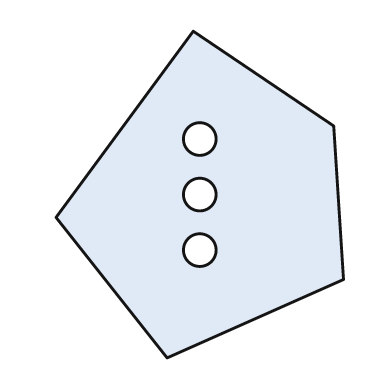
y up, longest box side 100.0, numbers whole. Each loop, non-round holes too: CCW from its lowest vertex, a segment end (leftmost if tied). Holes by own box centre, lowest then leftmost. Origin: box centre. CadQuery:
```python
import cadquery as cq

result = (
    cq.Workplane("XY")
    .moveTo(-10.0, -50.0)
    .lineTo(44.0, -26.0)
    .lineTo(41.0, 21.0)
    .lineTo(-2.0, 50.0)
    .lineTo(-44.0, -7.0)
    .close()
    .moveTo(0.0, -17.0)
    .circle(5.0)
    .moveTo(0.0, 0.0)
    .circle(5.0)
    .moveTo(0.0, 17.0)
    .circle(5.0)
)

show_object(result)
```